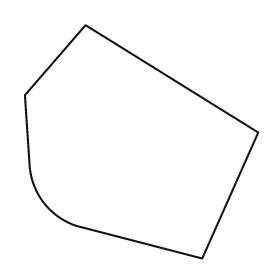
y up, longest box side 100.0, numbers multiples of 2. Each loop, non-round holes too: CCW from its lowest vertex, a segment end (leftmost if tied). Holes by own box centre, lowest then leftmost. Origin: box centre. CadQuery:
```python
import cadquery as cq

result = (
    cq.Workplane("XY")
    .moveTo(26.0, -50.0)
    .lineTo(50.0, 4.0)
    .lineTo(-24.0, 50.0)
    .lineTo(-50.0, 20.0)
    .lineTo(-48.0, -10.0)
    .threePointArc((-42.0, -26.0), (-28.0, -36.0))
    .close()
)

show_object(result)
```